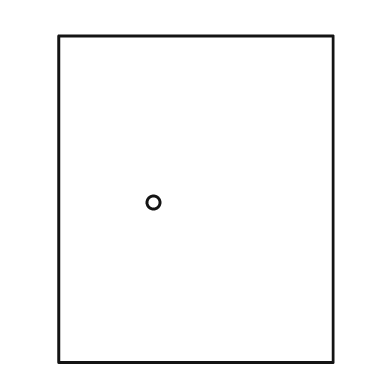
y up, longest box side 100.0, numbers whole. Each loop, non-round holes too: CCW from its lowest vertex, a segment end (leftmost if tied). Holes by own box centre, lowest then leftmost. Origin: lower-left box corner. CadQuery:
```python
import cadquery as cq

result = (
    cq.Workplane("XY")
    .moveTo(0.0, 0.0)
    .lineTo(84.0, 0.0)
    .lineTo(84.0, 100.0)
    .lineTo(0.0, 100.0)
    .close()
    .moveTo(29.0, 49.0)
    .circle(2.0)
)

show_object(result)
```